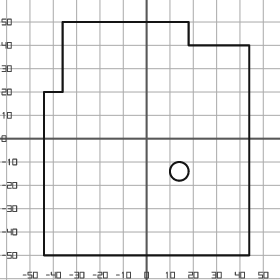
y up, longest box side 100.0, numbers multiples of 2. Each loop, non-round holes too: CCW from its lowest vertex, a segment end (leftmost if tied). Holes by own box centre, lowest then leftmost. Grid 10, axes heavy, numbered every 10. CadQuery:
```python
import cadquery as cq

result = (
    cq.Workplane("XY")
    .moveTo(-44.0, -50.0)
    .lineTo(44.0, -50.0)
    .lineTo(44.0, 40.0)
    .lineTo(18.0, 40.0)
    .lineTo(18.0, 50.0)
    .lineTo(-36.0, 50.0)
    .lineTo(-36.0, 20.0)
    .lineTo(-44.0, 20.0)
    .close()
    .moveTo(14.0, -14.0)
    .circle(4.0)
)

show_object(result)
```